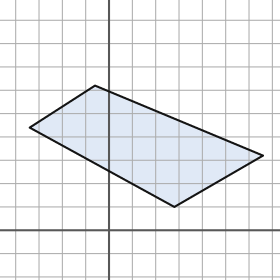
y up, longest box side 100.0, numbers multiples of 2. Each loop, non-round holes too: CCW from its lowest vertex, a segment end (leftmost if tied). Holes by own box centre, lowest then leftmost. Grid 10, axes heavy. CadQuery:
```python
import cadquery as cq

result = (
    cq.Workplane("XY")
    .moveTo(28.0, 10.0)
    .lineTo(66.0, 32.0)
    .lineTo(-6.0, 62.0)
    .lineTo(-34.0, 44.0)
    .close()
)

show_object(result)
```